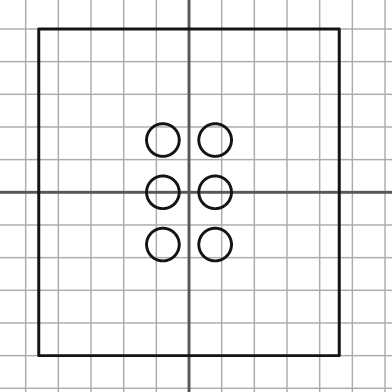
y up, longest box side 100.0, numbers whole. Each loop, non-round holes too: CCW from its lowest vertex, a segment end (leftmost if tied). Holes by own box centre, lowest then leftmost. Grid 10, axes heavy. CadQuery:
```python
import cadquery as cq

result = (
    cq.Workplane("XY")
    .moveTo(-46.0, -50.0)
    .lineTo(46.0, -50.0)
    .lineTo(46.0, 50.0)
    .lineTo(-46.0, 50.0)
    .close()
    .moveTo(-8.0, -16.0)
    .circle(5.0)
    .moveTo(8.0, -16.0)
    .circle(5.0)
    .moveTo(-8.0, 0.0)
    .circle(5.0)
    .moveTo(8.0, 0.0)
    .circle(5.0)
    .moveTo(-8.0, 16.0)
    .circle(5.0)
    .moveTo(8.0, 16.0)
    .circle(5.0)
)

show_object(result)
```